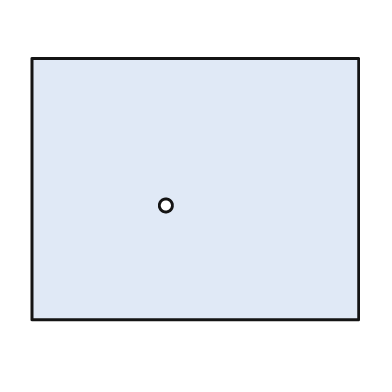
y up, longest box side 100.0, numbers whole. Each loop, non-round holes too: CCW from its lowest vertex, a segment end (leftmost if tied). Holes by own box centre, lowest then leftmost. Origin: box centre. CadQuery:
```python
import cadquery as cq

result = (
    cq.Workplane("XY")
    .moveTo(-50.0, -40.0)
    .lineTo(50.0, -40.0)
    .lineTo(50.0, 40.0)
    .lineTo(-50.0, 40.0)
    .close()
    .moveTo(-9.0, -5.0)
    .circle(2.0)
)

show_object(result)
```